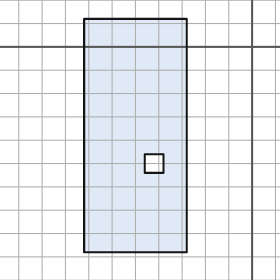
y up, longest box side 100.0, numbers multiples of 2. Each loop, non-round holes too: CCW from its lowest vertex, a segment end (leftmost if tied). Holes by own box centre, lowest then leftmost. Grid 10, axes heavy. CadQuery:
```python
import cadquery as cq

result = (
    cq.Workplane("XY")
    .moveTo(-72.0, -88.0)
    .lineTo(-28.0, -88.0)
    .lineTo(-28.0, 12.0)
    .lineTo(-72.0, 12.0)
    .close()
    .moveTo(-46.0, -54.0)
    .lineTo(-38.0, -54.0)
    .lineTo(-38.0, -46.0)
    .lineTo(-46.0, -46.0)
    .close()
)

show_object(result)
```